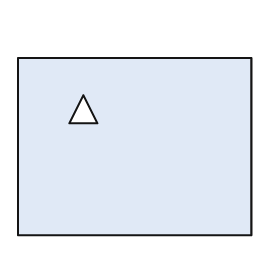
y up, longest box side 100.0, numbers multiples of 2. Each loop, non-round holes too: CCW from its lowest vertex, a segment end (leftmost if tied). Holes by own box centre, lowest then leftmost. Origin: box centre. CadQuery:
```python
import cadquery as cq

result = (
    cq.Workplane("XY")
    .moveTo(-50.0, -38.0)
    .lineTo(50.0, -38.0)
    .lineTo(50.0, 38.0)
    .lineTo(-50.0, 38.0)
    .close()
    .moveTo(-28.0, 10.0)
    .lineTo(-16.0, 10.0)
    .lineTo(-22.0, 22.0)
    .close()
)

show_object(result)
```